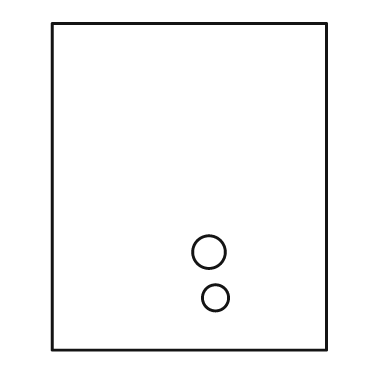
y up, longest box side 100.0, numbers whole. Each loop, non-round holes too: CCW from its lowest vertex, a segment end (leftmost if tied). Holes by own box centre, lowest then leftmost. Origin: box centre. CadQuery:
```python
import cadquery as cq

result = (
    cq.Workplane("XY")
    .moveTo(-42.0, -50.0)
    .lineTo(42.0, -50.0)
    .lineTo(42.0, 50.0)
    .lineTo(-42.0, 50.0)
    .close()
    .moveTo(8.0, -34.0)
    .circle(4.0)
    .moveTo(6.0, -20.0)
    .circle(5.0)
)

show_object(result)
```